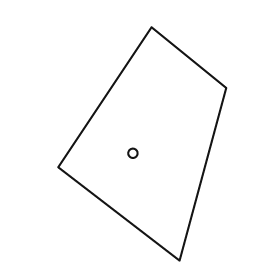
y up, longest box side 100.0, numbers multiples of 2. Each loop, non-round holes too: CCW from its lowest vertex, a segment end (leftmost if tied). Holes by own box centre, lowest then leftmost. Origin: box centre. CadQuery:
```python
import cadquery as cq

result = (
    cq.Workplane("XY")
    .moveTo(16.0, -50.0)
    .lineTo(36.0, 24.0)
    .lineTo(4.0, 50.0)
    .lineTo(-36.0, -10.0)
    .close()
    .moveTo(-4.0, -4.0)
    .circle(2.0)
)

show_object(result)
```